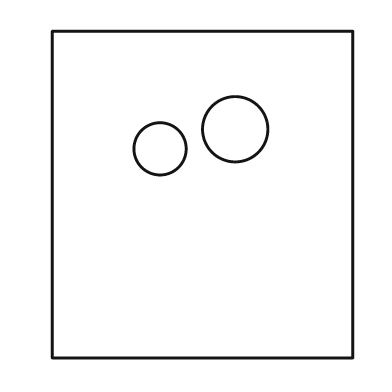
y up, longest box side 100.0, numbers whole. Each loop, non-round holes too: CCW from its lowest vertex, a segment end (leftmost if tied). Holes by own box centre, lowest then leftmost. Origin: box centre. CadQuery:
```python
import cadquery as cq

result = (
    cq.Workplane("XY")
    .moveTo(-46.0, -50.0)
    .lineTo(46.0, -50.0)
    .lineTo(46.0, 50.0)
    .lineTo(-46.0, 50.0)
    .close()
    .moveTo(-13.0, 14.0)
    .circle(8.0)
    .moveTo(10.0, 20.0)
    .circle(10.0)
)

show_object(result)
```